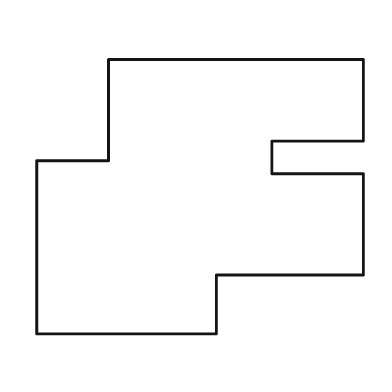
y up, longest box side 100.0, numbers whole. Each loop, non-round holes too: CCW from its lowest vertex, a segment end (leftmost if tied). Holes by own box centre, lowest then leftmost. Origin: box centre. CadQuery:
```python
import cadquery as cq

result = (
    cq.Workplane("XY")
    .moveTo(-50.0, -42.0)
    .lineTo(5.0, -42.0)
    .lineTo(5.0, -24.0)
    .lineTo(50.0, -24.0)
    .lineTo(50.0, 7.0)
    .lineTo(22.0, 7.0)
    .lineTo(22.0, 17.0)
    .lineTo(50.0, 17.0)
    .lineTo(50.0, 42.0)
    .lineTo(-28.0, 42.0)
    .lineTo(-28.0, 11.0)
    .lineTo(-50.0, 11.0)
    .close()
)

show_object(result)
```